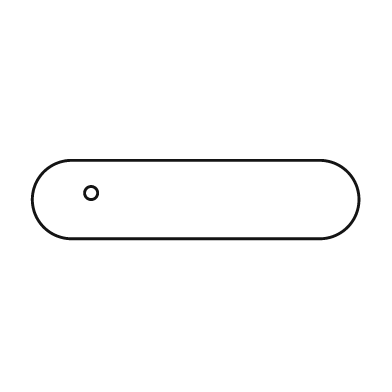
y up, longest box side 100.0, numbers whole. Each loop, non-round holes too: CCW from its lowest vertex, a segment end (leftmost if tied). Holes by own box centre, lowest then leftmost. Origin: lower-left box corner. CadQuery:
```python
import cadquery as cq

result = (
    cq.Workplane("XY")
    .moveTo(12.0, 0.0)
    .lineTo(88.0, 0.0)
    .threePointArc((100.0, 12.0), (88.0, 24.0))
    .lineTo(12.0, 24.0)
    .threePointArc((0.0, 12.0), (12.0, 0.0))
    .close()
    .moveTo(18.0, 14.0)
    .circle(2.0)
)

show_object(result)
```